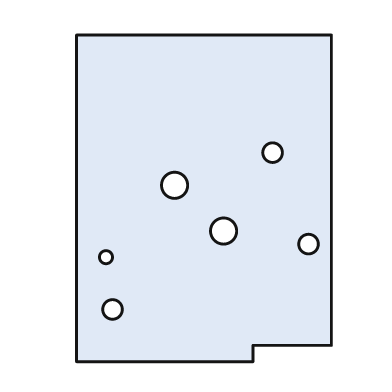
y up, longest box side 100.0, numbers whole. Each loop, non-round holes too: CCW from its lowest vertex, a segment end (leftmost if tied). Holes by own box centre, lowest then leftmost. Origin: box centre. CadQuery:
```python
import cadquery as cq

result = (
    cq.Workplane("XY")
    .moveTo(-39.0, -50.0)
    .lineTo(15.0, -50.0)
    .lineTo(15.0, -45.0)
    .lineTo(39.0, -45.0)
    .lineTo(39.0, 50.0)
    .lineTo(-39.0, 50.0)
    .close()
    .moveTo(-28.0, -34.0)
    .circle(3.0)
    .moveTo(-30.0, -18.0)
    .circle(2.0)
    .moveTo(32.0, -14.0)
    .circle(3.0)
    .moveTo(6.0, -10.0)
    .circle(4.0)
    .moveTo(-9.0, 4.0)
    .circle(4.0)
    .moveTo(21.0, 14.0)
    .circle(3.0)
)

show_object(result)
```